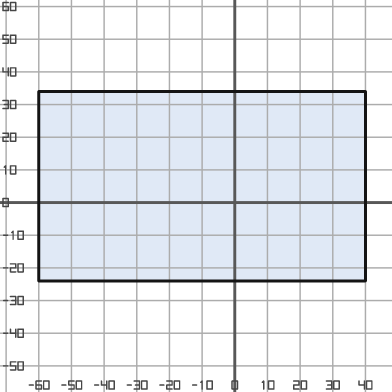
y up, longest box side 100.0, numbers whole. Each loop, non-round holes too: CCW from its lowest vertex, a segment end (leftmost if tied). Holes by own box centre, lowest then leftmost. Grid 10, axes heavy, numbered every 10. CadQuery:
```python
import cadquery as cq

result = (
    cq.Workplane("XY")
    .moveTo(-60.0, -24.0)
    .lineTo(40.0, -24.0)
    .lineTo(40.0, 34.0)
    .lineTo(-60.0, 34.0)
    .close()
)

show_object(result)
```